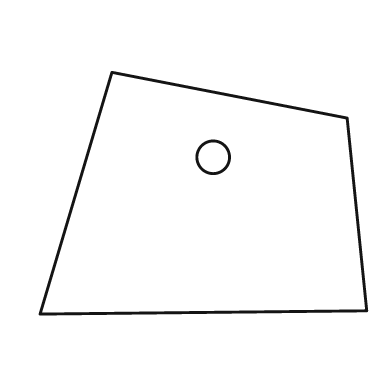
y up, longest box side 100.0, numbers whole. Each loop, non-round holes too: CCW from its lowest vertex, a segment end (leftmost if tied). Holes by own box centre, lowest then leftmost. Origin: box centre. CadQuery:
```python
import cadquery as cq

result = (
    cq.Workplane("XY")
    .moveTo(-50.0, -37.0)
    .lineTo(50.0, -36.0)
    .lineTo(44.0, 23.0)
    .lineTo(-28.0, 37.0)
    .close()
    .moveTo(3.0, 11.0)
    .circle(5.0)
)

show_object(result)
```